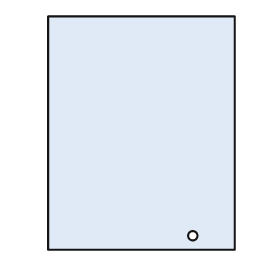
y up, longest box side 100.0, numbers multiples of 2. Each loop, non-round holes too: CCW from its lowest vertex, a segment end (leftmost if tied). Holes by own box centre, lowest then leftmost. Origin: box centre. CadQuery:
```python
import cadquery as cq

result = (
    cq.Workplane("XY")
    .moveTo(-40.0, -50.0)
    .lineTo(40.0, -50.0)
    .lineTo(40.0, 50.0)
    .lineTo(-40.0, 50.0)
    .close()
    .moveTo(22.0, -44.0)
    .circle(2.0)
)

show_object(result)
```